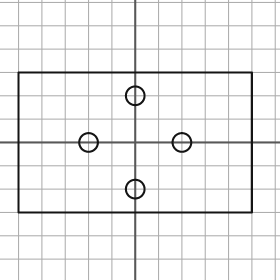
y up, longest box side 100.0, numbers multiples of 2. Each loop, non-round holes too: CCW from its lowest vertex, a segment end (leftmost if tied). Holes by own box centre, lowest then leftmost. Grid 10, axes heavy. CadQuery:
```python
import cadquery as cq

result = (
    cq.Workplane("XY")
    .moveTo(-50.0, -30.0)
    .lineTo(50.0, -30.0)
    .lineTo(50.0, 30.0)
    .lineTo(-50.0, 30.0)
    .close()
    .moveTo(0.0, -20.0)
    .circle(4.0)
    .moveTo(-20.0, 0.0)
    .circle(4.0)
    .moveTo(20.0, 0.0)
    .circle(4.0)
    .moveTo(0.0, 20.0)
    .circle(4.0)
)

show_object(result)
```